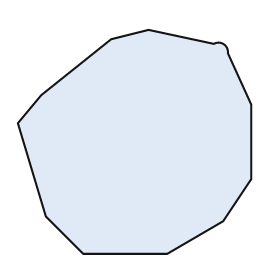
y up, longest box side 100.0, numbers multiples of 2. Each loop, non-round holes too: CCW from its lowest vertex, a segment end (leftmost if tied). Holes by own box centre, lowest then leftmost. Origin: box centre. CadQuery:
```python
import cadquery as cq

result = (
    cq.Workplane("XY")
    .moveTo(-22.0, -48.0)
    .lineTo(14.0, -48.0)
    .lineTo(38.0, -34.0)
    .lineTo(50.0, -16.0)
    .lineTo(50.0, 16.0)
    .lineTo(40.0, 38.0)
    .threePointArc((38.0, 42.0), (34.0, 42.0))
    .lineTo(6.0, 48.0)
    .lineTo(-10.0, 44.0)
    .lineTo(-40.0, 20.0)
    .lineTo(-50.0, 8.0)
    .lineTo(-38.0, -32.0)
    .close()
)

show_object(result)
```